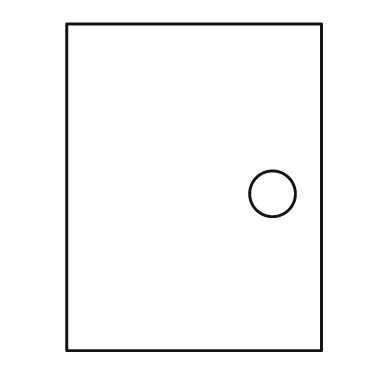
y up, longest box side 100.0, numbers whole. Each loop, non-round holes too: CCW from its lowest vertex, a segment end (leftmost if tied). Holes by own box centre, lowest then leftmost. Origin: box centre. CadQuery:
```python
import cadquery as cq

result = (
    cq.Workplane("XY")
    .moveTo(-39.0, -50.0)
    .lineTo(39.0, -50.0)
    .lineTo(39.0, 50.0)
    .lineTo(-39.0, 50.0)
    .close()
    .moveTo(24.0, -2.0)
    .circle(7.0)
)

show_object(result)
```